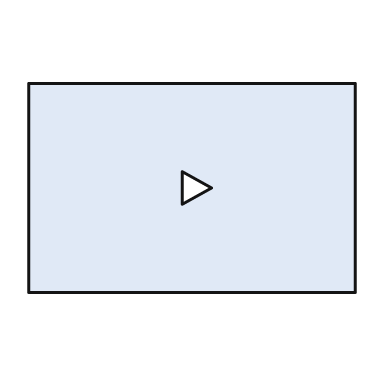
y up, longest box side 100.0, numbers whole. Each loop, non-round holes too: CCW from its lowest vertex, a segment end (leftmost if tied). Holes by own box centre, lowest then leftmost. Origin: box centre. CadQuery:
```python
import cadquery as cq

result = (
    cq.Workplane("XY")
    .moveTo(-50.0, -32.0)
    .lineTo(50.0, -32.0)
    .lineTo(50.0, 32.0)
    .lineTo(-50.0, 32.0)
    .close()
    .moveTo(-3.0, -5.0)
    .lineTo(6.0, 0.0)
    .lineTo(-3.0, 5.0)
    .close()
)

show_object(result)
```